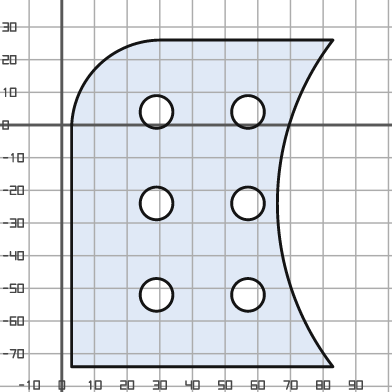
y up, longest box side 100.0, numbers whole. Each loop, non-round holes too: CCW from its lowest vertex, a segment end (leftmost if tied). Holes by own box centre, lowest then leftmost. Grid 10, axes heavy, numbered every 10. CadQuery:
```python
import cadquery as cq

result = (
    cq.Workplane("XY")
    .moveTo(3.0, -74.0)
    .lineTo(83.0, -74.0)
    .threePointArc((66.0, -24.0), (83.0, 26.0))
    .lineTo(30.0, 26.0)
    .threePointArc((11.0, 18.0), (3.0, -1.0))
    .close()
    .moveTo(29.0, -52.0)
    .circle(5.0)
    .moveTo(57.0, -52.0)
    .circle(5.0)
    .moveTo(29.0, -24.0)
    .circle(5.0)
    .moveTo(57.0, -24.0)
    .circle(5.0)
    .moveTo(29.0, 4.0)
    .circle(5.0)
    .moveTo(57.0, 4.0)
    .circle(5.0)
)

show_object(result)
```